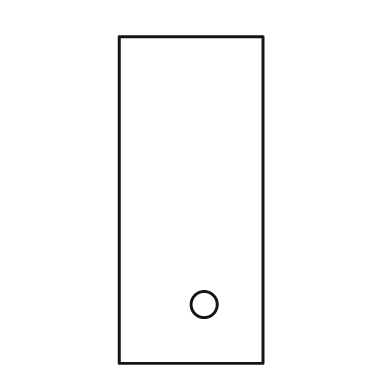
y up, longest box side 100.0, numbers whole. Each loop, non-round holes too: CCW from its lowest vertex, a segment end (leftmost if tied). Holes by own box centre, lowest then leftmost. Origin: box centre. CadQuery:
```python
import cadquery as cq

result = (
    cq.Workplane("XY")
    .moveTo(-22.0, -50.0)
    .lineTo(22.0, -50.0)
    .lineTo(22.0, 50.0)
    .lineTo(-22.0, 50.0)
    .close()
    .moveTo(4.0, -32.0)
    .circle(4.0)
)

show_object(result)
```